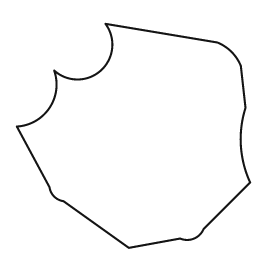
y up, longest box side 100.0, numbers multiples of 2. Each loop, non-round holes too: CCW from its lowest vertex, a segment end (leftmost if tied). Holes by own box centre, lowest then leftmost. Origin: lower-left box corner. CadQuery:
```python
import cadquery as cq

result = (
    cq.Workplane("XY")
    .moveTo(48.0, 0.0)
    .lineTo(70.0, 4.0)
    .threePointArc((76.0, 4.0), (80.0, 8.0))
    .lineTo(100.0, 28.0)
    .threePointArc((96.0, 44.0), (98.0, 60.0))
    .lineTo(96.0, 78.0)
    .threePointArc((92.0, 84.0), (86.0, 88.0))
    .lineTo(38.0, 96.0)
    .threePointArc((36.0, 76.0), (16.0, 76.0))
    .threePointArc((14.0, 60.0), (0.0, 52.0))
    .lineTo(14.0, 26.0)
    .threePointArc((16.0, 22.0), (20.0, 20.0))
    .close()
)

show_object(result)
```